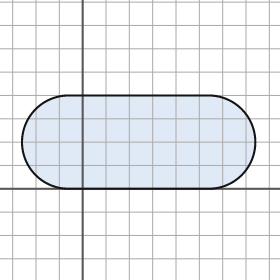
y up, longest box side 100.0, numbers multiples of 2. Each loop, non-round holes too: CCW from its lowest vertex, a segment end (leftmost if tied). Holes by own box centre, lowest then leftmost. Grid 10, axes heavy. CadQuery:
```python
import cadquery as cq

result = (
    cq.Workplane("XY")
    .moveTo(-6.0, 0.0)
    .lineTo(54.0, 0.0)
    .threePointArc((74.0, 20.0), (54.0, 40.0))
    .lineTo(-6.0, 40.0)
    .threePointArc((-26.0, 20.0), (-6.0, 0.0))
    .close()
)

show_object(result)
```